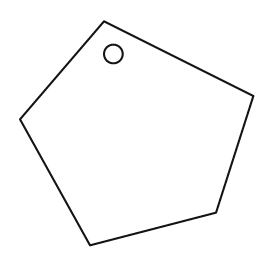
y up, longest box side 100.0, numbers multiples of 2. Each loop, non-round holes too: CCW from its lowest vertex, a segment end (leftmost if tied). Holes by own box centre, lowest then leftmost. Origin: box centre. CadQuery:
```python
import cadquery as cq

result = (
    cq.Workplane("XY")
    .moveTo(-20.0, -48.0)
    .lineTo(34.0, -34.0)
    .lineTo(50.0, 16.0)
    .lineTo(-14.0, 48.0)
    .lineTo(-50.0, 6.0)
    .close()
    .moveTo(-10.0, 34.0)
    .circle(4.0)
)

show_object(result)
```